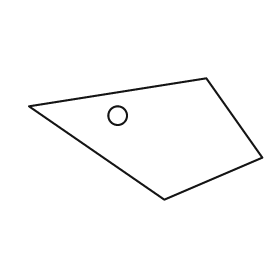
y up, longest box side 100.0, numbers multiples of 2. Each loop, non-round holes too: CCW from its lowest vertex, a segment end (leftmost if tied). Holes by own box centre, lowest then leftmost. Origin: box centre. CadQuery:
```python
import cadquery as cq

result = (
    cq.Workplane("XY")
    .moveTo(8.0, -26.0)
    .lineTo(50.0, -8.0)
    .lineTo(26.0, 26.0)
    .lineTo(-50.0, 14.0)
    .close()
    .moveTo(-12.0, 10.0)
    .circle(4.0)
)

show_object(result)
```